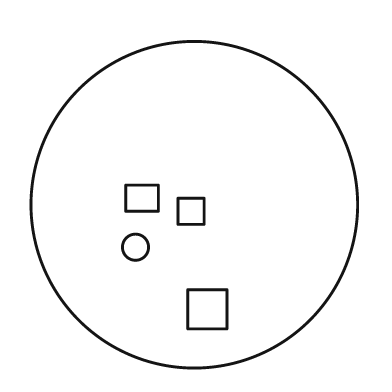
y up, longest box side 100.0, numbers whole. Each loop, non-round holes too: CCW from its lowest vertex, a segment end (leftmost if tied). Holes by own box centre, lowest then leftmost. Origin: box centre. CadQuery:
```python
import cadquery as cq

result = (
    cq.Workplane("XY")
    .moveTo(0.0, 0.0)
    .circle(50.0)
    .moveTo(-2.0, -38.0)
    .lineTo(10.0, -38.0)
    .lineTo(10.0, -26.0)
    .lineTo(-2.0, -26.0)
    .close()
    .moveTo(-18.0, -13.0)
    .circle(4.0)
    .moveTo(-5.0, -6.0)
    .lineTo(3.0, -6.0)
    .lineTo(3.0, 2.0)
    .lineTo(-5.0, 2.0)
    .close()
    .moveTo(-21.0, -2.0)
    .lineTo(-11.0, -2.0)
    .lineTo(-11.0, 6.0)
    .lineTo(-21.0, 6.0)
    .close()
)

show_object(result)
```